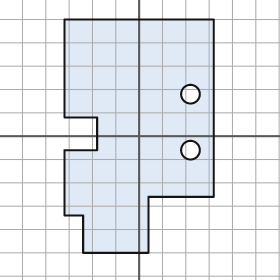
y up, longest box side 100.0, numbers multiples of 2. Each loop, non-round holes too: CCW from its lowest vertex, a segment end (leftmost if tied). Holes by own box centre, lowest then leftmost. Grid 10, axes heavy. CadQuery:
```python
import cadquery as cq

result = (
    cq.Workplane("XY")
    .moveTo(-24.0, -50.0)
    .lineTo(4.0, -50.0)
    .lineTo(4.0, -26.0)
    .lineTo(32.0, -26.0)
    .lineTo(32.0, 50.0)
    .lineTo(-32.0, 50.0)
    .lineTo(-32.0, 8.0)
    .lineTo(-18.0, 8.0)
    .lineTo(-18.0, -6.0)
    .lineTo(-32.0, -6.0)
    .lineTo(-32.0, -34.0)
    .lineTo(-24.0, -34.0)
    .close()
    .moveTo(22.0, -6.0)
    .circle(4.0)
    .moveTo(22.0, 18.0)
    .circle(4.0)
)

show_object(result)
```